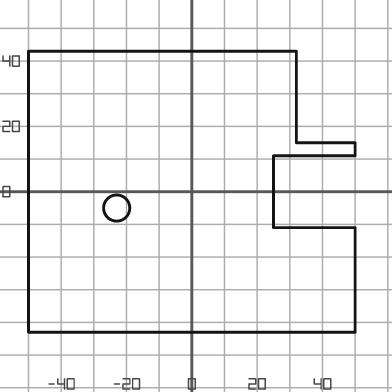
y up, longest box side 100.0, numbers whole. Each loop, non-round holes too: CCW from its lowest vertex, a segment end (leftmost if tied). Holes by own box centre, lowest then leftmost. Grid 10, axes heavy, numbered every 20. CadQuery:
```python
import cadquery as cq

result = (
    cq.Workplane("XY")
    .moveTo(-50.0, -43.0)
    .lineTo(50.0, -43.0)
    .lineTo(50.0, -11.0)
    .lineTo(25.0, -11.0)
    .lineTo(25.0, 11.0)
    .lineTo(50.0, 11.0)
    .lineTo(50.0, 15.0)
    .lineTo(32.0, 15.0)
    .lineTo(32.0, 43.0)
    .lineTo(-50.0, 43.0)
    .close()
    .moveTo(-23.0, -5.0)
    .circle(4.0)
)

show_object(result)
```